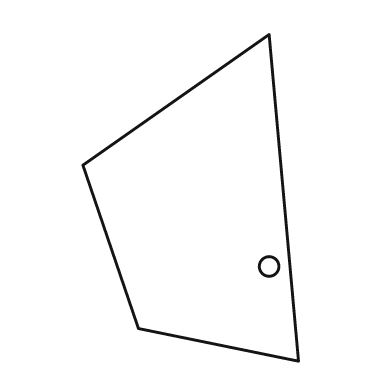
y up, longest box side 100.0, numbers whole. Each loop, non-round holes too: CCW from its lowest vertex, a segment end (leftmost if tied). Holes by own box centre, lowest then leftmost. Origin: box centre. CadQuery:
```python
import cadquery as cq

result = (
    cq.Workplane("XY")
    .moveTo(33.0, -50.0)
    .lineTo(24.0, 50.0)
    .lineTo(-33.0, 10.0)
    .lineTo(-16.0, -40.0)
    .close()
    .moveTo(24.0, -21.0)
    .circle(3.0)
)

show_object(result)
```